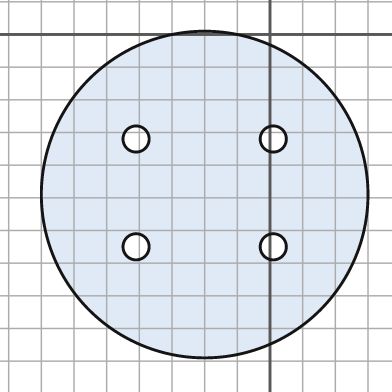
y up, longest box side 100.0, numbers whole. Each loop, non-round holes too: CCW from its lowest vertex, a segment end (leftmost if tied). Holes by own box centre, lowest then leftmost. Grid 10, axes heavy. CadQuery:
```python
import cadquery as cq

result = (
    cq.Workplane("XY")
    .moveTo(-20.0, -49.0)
    .circle(50.0)
    .moveTo(-41.0, -65.0)
    .circle(4.0)
    .moveTo(1.0, -65.0)
    .circle(4.0)
    .moveTo(-41.0, -32.0)
    .circle(4.0)
    .moveTo(1.0, -32.0)
    .circle(4.0)
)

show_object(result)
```